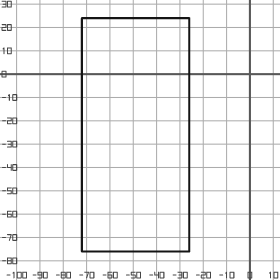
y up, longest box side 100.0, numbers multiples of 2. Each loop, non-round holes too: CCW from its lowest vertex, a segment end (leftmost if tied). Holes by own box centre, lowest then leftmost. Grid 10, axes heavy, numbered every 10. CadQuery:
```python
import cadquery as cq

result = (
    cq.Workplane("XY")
    .moveTo(-72.0, -76.0)
    .lineTo(-26.0, -76.0)
    .lineTo(-26.0, 24.0)
    .lineTo(-72.0, 24.0)
    .close()
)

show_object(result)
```